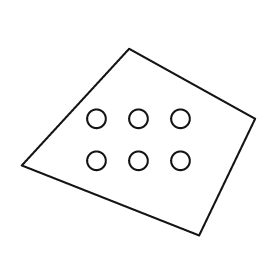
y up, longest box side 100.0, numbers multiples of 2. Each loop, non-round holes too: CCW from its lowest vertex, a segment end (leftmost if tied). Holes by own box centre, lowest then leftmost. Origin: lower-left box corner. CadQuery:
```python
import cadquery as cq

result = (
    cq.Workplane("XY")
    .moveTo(76.0, 0.0)
    .lineTo(100.0, 50.0)
    .lineTo(46.0, 80.0)
    .lineTo(0.0, 30.0)
    .close()
    .moveTo(32.0, 32.0)
    .circle(4.0)
    .moveTo(50.0, 32.0)
    .circle(4.0)
    .moveTo(68.0, 32.0)
    .circle(4.0)
    .moveTo(32.0, 50.0)
    .circle(4.0)
    .moveTo(50.0, 50.0)
    .circle(4.0)
    .moveTo(68.0, 50.0)
    .circle(4.0)
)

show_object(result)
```